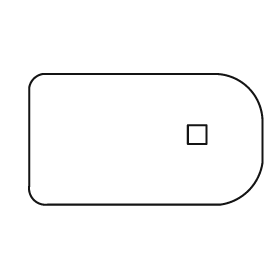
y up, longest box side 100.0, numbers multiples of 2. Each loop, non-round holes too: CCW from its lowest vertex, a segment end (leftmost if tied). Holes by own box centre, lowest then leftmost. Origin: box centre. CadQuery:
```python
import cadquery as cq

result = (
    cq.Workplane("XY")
    .moveTo(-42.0, -28.0)
    .lineTo(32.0, -28.0)
    .threePointArc((44.0, -22.0), (50.0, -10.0))
    .lineTo(50.0, 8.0)
    .threePointArc((44.0, 22.0), (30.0, 28.0))
    .lineTo(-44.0, 28.0)
    .threePointArc((-48.0, 26.0), (-50.0, 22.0))
    .lineTo(-50.0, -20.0)
    .threePointArc((-48.0, -26.0), (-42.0, -28.0))
    .close()
    .moveTo(18.0, -2.0)
    .lineTo(26.0, -2.0)
    .lineTo(26.0, 6.0)
    .lineTo(18.0, 6.0)
    .close()
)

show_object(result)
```